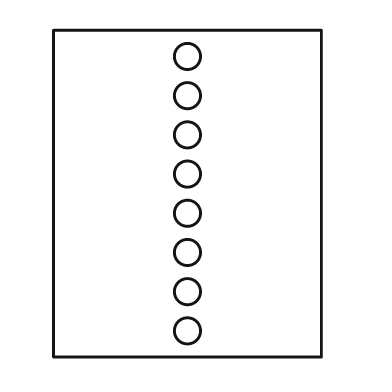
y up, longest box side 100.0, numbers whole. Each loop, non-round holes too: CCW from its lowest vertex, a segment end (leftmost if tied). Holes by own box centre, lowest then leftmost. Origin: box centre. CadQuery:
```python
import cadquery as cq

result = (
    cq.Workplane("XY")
    .moveTo(-41.0, -50.0)
    .lineTo(41.0, -50.0)
    .lineTo(41.0, 50.0)
    .lineTo(-41.0, 50.0)
    .close()
    .moveTo(0.0, -42.0)
    .circle(4.0)
    .moveTo(0.0, -30.0)
    .circle(4.0)
    .moveTo(0.0, -18.0)
    .circle(4.0)
    .moveTo(0.0, -6.0)
    .circle(4.0)
    .moveTo(0.0, 6.0)
    .circle(4.0)
    .moveTo(0.0, 18.0)
    .circle(4.0)
    .moveTo(0.0, 30.0)
    .circle(4.0)
    .moveTo(0.0, 42.0)
    .circle(4.0)
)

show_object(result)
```